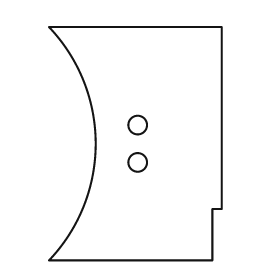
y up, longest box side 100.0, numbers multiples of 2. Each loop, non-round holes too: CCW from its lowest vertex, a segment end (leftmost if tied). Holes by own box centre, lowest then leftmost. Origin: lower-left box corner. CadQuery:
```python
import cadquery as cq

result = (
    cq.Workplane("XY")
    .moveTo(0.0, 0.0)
    .lineTo(70.0, 0.0)
    .lineTo(70.0, 22.0)
    .lineTo(74.0, 22.0)
    .lineTo(74.0, 100.0)
    .lineTo(0.0, 100.0)
    .threePointArc((20.0, 50.0), (0.0, 0.0))
    .close()
    .moveTo(38.0, 42.0)
    .circle(4.0)
    .moveTo(38.0, 58.0)
    .circle(4.0)
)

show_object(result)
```